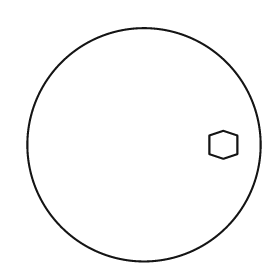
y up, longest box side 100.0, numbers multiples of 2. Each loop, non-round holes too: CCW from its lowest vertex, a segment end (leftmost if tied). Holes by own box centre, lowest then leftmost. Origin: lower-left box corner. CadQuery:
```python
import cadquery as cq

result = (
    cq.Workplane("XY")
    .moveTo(50.0, 50.0)
    .circle(50.0)
    .moveTo(84.0, 44.0)
    .lineTo(90.0, 46.0)
    .lineTo(90.0, 54.0)
    .lineTo(84.0, 56.0)
    .lineTo(78.0, 54.0)
    .lineTo(78.0, 46.0)
    .close()
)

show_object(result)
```